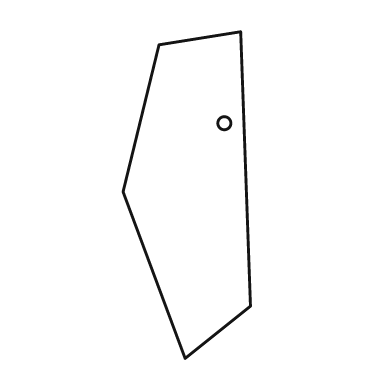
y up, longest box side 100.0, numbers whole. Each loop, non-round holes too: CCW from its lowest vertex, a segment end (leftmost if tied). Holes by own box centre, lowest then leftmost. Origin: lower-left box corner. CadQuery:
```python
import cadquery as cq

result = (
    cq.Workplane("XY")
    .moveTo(19.0, 0.0)
    .lineTo(39.0, 16.0)
    .lineTo(36.0, 100.0)
    .lineTo(11.0, 96.0)
    .lineTo(0.0, 51.0)
    .close()
    .moveTo(31.0, 72.0)
    .circle(2.0)
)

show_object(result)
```